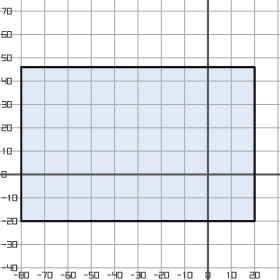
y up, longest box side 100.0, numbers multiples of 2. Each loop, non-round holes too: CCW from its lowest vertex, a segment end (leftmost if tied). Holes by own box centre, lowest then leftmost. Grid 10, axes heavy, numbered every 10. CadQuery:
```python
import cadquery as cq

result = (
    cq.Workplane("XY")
    .moveTo(-80.0, -20.0)
    .lineTo(20.0, -20.0)
    .lineTo(20.0, 46.0)
    .lineTo(-80.0, 46.0)
    .close()
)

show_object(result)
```